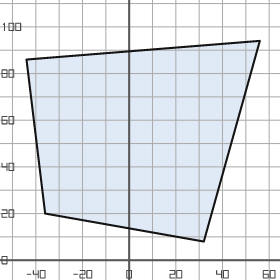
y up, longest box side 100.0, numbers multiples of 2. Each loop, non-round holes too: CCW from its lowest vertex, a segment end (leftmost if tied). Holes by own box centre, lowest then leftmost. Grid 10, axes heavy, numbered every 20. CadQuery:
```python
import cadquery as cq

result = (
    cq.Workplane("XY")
    .moveTo(32.0, 8.0)
    .lineTo(56.0, 94.0)
    .lineTo(-44.0, 86.0)
    .lineTo(-36.0, 20.0)
    .close()
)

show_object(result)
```